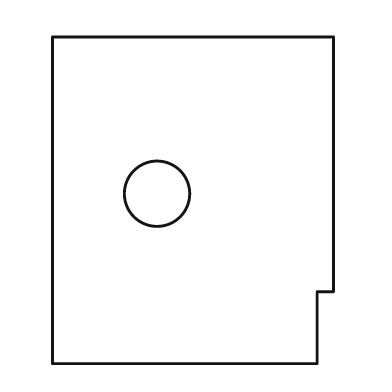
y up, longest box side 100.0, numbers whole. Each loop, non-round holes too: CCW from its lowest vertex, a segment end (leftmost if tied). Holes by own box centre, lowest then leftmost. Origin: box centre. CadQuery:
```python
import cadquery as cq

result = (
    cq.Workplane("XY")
    .moveTo(-43.0, -50.0)
    .lineTo(38.0, -50.0)
    .lineTo(38.0, -28.0)
    .lineTo(43.0, -28.0)
    .lineTo(43.0, 50.0)
    .lineTo(-43.0, 50.0)
    .close()
    .moveTo(-11.0, 2.0)
    .circle(10.0)
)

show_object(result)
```